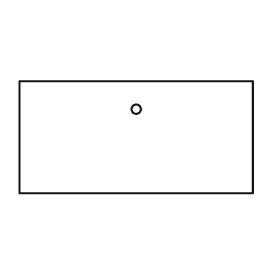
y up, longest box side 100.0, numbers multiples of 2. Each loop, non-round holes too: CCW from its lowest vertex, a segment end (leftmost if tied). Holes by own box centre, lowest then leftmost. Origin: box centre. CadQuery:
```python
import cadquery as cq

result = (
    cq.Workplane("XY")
    .moveTo(-50.0, -24.0)
    .lineTo(50.0, -24.0)
    .lineTo(50.0, 24.0)
    .lineTo(-50.0, 24.0)
    .close()
    .moveTo(0.0, 12.0)
    .circle(2.0)
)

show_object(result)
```